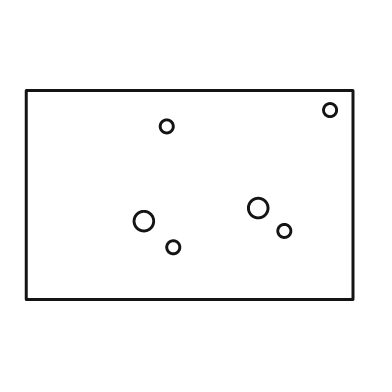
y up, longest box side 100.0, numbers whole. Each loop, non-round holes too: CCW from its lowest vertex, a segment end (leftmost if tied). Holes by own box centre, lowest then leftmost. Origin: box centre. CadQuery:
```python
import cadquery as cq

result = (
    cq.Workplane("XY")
    .moveTo(-50.0, -32.0)
    .lineTo(50.0, -32.0)
    .lineTo(50.0, 32.0)
    .lineTo(-50.0, 32.0)
    .close()
    .moveTo(-5.0, -16.0)
    .circle(2.0)
    .moveTo(29.0, -11.0)
    .circle(2.0)
    .moveTo(-14.0, -8.0)
    .circle(3.0)
    .moveTo(21.0, -4.0)
    .circle(3.0)
    .moveTo(-7.0, 21.0)
    .circle(2.0)
    .moveTo(43.0, 26.0)
    .circle(2.0)
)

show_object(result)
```